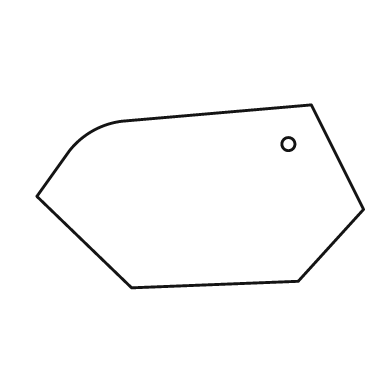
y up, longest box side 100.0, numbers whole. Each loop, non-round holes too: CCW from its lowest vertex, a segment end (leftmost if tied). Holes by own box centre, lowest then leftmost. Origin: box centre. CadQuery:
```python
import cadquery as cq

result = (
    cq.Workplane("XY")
    .moveTo(-21.0, -28.0)
    .lineTo(30.0, -26.0)
    .lineTo(50.0, -4.0)
    .lineTo(34.0, 28.0)
    .lineTo(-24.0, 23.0)
    .threePointArc((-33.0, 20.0), (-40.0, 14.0))
    .lineTo(-50.0, 0.0)
    .close()
    .moveTo(27.0, 16.0)
    .circle(2.0)
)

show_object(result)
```